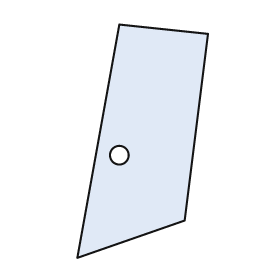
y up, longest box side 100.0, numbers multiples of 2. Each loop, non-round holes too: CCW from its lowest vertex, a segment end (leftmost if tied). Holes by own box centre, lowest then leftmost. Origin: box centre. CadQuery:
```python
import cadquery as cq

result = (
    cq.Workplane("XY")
    .moveTo(-28.0, -50.0)
    .lineTo(18.0, -34.0)
    .lineTo(28.0, 46.0)
    .lineTo(-10.0, 50.0)
    .close()
    .moveTo(-10.0, -6.0)
    .circle(4.0)
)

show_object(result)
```